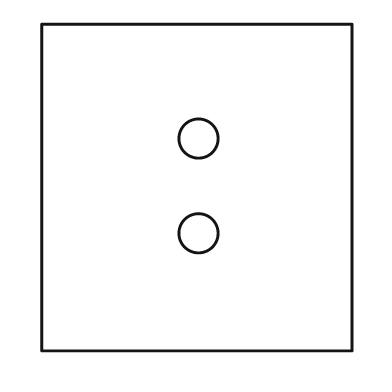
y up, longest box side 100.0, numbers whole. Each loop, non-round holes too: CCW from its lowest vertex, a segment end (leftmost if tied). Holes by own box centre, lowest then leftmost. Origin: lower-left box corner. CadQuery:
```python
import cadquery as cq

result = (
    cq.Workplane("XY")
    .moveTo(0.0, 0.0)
    .lineTo(95.0, 0.0)
    .lineTo(95.0, 100.0)
    .lineTo(0.0, 100.0)
    .close()
    .moveTo(48.0, 36.0)
    .circle(6.0)
    .moveTo(48.0, 65.0)
    .circle(6.0)
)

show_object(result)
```